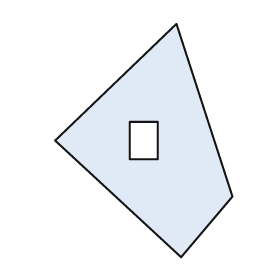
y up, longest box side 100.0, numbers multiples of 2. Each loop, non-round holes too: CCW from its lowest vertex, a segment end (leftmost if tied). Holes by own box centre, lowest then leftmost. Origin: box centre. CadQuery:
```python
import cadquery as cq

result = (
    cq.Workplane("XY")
    .moveTo(16.0, -50.0)
    .lineTo(38.0, -24.0)
    .lineTo(14.0, 50.0)
    .lineTo(-38.0, 0.0)
    .close()
    .moveTo(-6.0, -8.0)
    .lineTo(6.0, -8.0)
    .lineTo(6.0, 8.0)
    .lineTo(-6.0, 8.0)
    .close()
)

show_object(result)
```